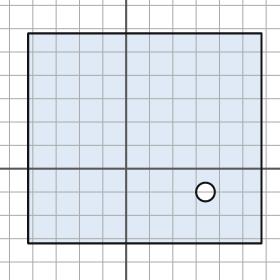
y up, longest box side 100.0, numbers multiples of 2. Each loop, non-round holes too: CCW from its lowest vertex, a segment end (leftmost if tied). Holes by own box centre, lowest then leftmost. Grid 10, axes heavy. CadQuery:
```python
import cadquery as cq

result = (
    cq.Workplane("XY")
    .moveTo(-42.0, -32.0)
    .lineTo(58.0, -32.0)
    .lineTo(58.0, 58.0)
    .lineTo(-42.0, 58.0)
    .close()
    .moveTo(34.0, -10.0)
    .circle(4.0)
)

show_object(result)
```